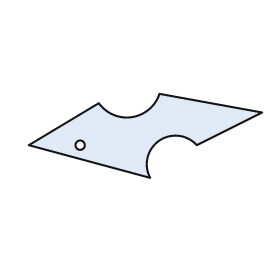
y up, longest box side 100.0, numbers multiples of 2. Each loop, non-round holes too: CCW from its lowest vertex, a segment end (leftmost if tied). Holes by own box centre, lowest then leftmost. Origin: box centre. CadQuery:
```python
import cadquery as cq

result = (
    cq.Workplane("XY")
    .moveTo(2.0, -18.0)
    .threePointArc((6.0, -2.0), (22.0, -4.0))
    .lineTo(50.0, 10.0)
    .lineTo(6.0, 18.0)
    .threePointArc((-6.0, 8.0), (-20.0, 14.0))
    .lineTo(-50.0, -4.0)
    .close()
    .moveTo(-28.0, -4.0)
    .circle(2.0)
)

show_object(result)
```